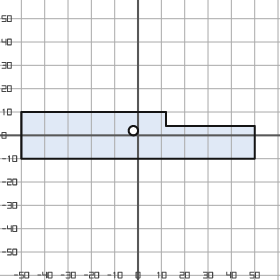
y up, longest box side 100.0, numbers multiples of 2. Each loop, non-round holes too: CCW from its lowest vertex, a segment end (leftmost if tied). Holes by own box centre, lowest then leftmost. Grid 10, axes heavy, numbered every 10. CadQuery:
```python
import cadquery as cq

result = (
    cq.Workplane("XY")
    .moveTo(-50.0, -10.0)
    .lineTo(50.0, -10.0)
    .lineTo(50.0, 4.0)
    .lineTo(12.0, 4.0)
    .lineTo(12.0, 10.0)
    .lineTo(-50.0, 10.0)
    .close()
    .moveTo(-2.0, 2.0)
    .circle(2.0)
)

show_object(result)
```